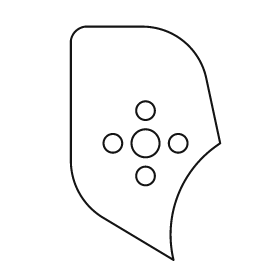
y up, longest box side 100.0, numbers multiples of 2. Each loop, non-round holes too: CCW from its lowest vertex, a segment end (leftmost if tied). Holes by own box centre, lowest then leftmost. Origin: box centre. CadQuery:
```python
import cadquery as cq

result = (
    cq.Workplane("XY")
    .moveTo(12.0, -50.0)
    .threePointArc((14.0, -22.0), (32.0, 0.0))
    .lineTo(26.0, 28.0)
    .threePointArc((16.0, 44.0), (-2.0, 50.0))
    .lineTo(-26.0, 50.0)
    .threePointArc((-30.0, 48.0), (-32.0, 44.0))
    .lineTo(-32.0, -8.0)
    .threePointArc((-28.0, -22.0), (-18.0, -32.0))
    .close()
    .moveTo(0.0, -14.0)
    .circle(4.0)
    .moveTo(-14.0, 0.0)
    .circle(4.0)
    .moveTo(0.0, 0.0)
    .circle(6.0)
    .moveTo(14.0, 0.0)
    .circle(4.0)
    .moveTo(0.0, 14.0)
    .circle(4.0)
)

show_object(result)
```